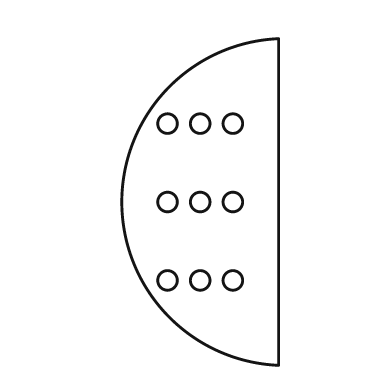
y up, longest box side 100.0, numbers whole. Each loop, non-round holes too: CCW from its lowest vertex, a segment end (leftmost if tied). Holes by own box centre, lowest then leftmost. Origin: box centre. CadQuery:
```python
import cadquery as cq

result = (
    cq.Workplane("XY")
    .moveTo(24.0, -50.0)
    .lineTo(24.0, 50.0)
    .threePointArc((-24.0, 0.0), (24.0, -50.0))
    .close()
    .moveTo(-10.0, -24.0)
    .circle(3.0)
    .moveTo(0.0, -24.0)
    .circle(3.0)
    .moveTo(10.0, -24.0)
    .circle(3.0)
    .moveTo(-10.0, 0.0)
    .circle(3.0)
    .moveTo(0.0, 0.0)
    .circle(3.0)
    .moveTo(10.0, 0.0)
    .circle(3.0)
    .moveTo(-10.0, 24.0)
    .circle(3.0)
    .moveTo(0.0, 24.0)
    .circle(3.0)
    .moveTo(10.0, 24.0)
    .circle(3.0)
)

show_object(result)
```